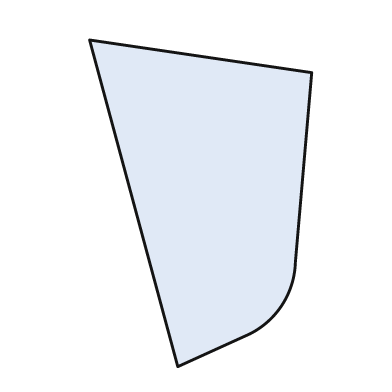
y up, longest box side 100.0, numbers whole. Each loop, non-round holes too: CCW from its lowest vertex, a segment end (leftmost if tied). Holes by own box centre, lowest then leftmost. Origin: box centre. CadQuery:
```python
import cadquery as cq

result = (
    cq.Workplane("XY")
    .moveTo(-7.0, -50.0)
    .lineTo(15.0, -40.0)
    .threePointArc((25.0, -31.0), (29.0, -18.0))
    .lineTo(34.0, 40.0)
    .lineTo(-34.0, 50.0)
    .close()
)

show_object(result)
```